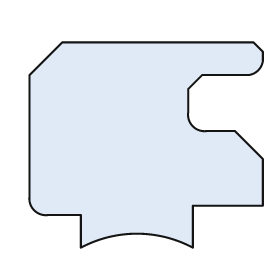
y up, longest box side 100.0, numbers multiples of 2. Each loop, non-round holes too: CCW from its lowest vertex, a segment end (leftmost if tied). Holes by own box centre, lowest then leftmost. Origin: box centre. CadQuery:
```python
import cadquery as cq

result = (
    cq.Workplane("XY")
    .moveTo(-28.0, -44.0)
    .threePointArc((-4.0, -38.0), (20.0, -44.0))
    .lineTo(20.0, -26.0)
    .lineTo(50.0, -26.0)
    .lineTo(50.0, -6.0)
    .lineTo(38.0, 6.0)
    .lineTo(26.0, 6.0)
    .threePointArc((20.0, 8.0), (18.0, 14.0))
    .lineTo(18.0, 24.0)
    .lineTo(24.0, 30.0)
    .lineTo(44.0, 30.0)
    .threePointArc((48.0, 32.0), (50.0, 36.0))
    .lineTo(50.0, 40.0)
    .lineTo(46.0, 44.0)
    .lineTo(-36.0, 44.0)
    .lineTo(-50.0, 30.0)
    .lineTo(-50.0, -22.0)
    .threePointArc((-48.0, -28.0), (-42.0, -30.0))
    .lineTo(-28.0, -30.0)
    .close()
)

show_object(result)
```